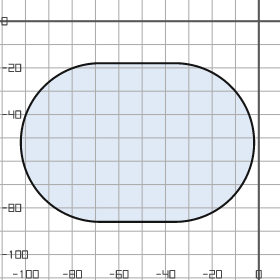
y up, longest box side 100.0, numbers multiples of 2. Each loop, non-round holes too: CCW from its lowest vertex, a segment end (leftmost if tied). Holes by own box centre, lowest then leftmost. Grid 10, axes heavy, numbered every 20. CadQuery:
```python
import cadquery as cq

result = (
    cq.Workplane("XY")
    .moveTo(-68.0, -86.0)
    .lineTo(-36.0, -86.0)
    .threePointArc((-2.0, -52.0), (-36.0, -18.0))
    .lineTo(-68.0, -18.0)
    .threePointArc((-102.0, -52.0), (-68.0, -86.0))
    .close()
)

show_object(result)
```